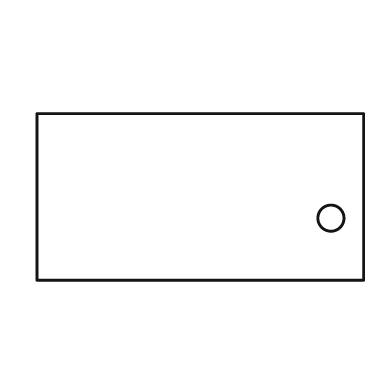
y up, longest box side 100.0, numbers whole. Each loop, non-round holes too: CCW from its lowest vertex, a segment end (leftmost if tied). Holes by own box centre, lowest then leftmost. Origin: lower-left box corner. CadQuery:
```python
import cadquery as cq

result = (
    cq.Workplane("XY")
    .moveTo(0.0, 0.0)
    .lineTo(100.0, 0.0)
    .lineTo(100.0, 51.0)
    .lineTo(0.0, 51.0)
    .close()
    .moveTo(90.0, 19.0)
    .circle(4.0)
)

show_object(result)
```